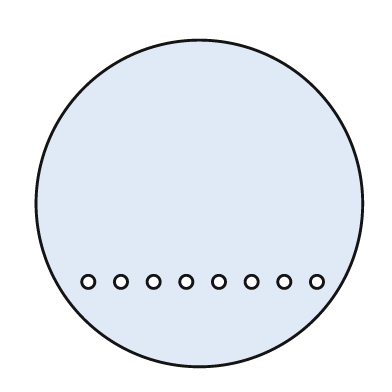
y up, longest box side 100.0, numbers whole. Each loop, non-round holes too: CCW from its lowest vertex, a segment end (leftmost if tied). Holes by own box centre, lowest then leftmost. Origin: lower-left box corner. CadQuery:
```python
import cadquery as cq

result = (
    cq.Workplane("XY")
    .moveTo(50.0, 50.0)
    .circle(50.0)
    .moveTo(16.0, 26.0)
    .circle(2.0)
    .moveTo(26.0, 26.0)
    .circle(2.0)
    .moveTo(36.0, 26.0)
    .circle(2.0)
    .moveTo(46.0, 26.0)
    .circle(2.0)
    .moveTo(56.0, 26.0)
    .circle(2.0)
    .moveTo(66.0, 26.0)
    .circle(2.0)
    .moveTo(76.0, 26.0)
    .circle(2.0)
    .moveTo(86.0, 26.0)
    .circle(2.0)
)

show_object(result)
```